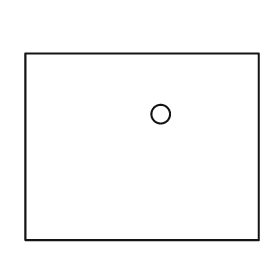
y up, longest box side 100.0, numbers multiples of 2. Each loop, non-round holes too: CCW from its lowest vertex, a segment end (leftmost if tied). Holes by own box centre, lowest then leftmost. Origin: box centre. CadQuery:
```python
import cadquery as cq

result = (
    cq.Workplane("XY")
    .moveTo(-50.0, -40.0)
    .lineTo(50.0, -40.0)
    .lineTo(50.0, 40.0)
    .lineTo(-50.0, 40.0)
    .close()
    .moveTo(8.0, 14.0)
    .circle(4.0)
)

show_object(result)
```